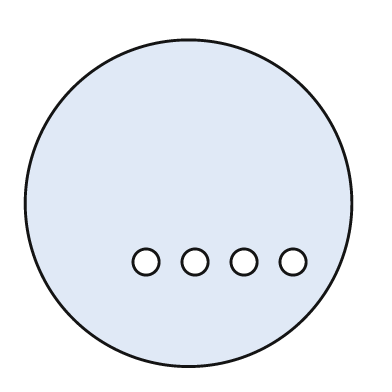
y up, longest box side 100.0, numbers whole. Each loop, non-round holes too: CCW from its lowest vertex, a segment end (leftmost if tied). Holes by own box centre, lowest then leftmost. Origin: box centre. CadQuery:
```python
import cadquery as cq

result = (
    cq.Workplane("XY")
    .moveTo(0.0, 0.0)
    .circle(50.0)
    .moveTo(-13.0, -18.0)
    .circle(4.0)
    .moveTo(2.0, -18.0)
    .circle(4.0)
    .moveTo(17.0, -18.0)
    .circle(4.0)
    .moveTo(32.0, -18.0)
    .circle(4.0)
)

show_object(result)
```